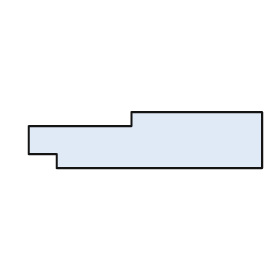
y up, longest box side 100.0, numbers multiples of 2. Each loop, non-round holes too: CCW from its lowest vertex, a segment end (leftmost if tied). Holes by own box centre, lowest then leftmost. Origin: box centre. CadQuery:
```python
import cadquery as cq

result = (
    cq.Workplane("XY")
    .moveTo(-38.0, -12.0)
    .lineTo(50.0, -12.0)
    .lineTo(50.0, 12.0)
    .lineTo(-6.0, 12.0)
    .lineTo(-6.0, 6.0)
    .lineTo(-50.0, 6.0)
    .lineTo(-50.0, -6.0)
    .lineTo(-38.0, -6.0)
    .close()
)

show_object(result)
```